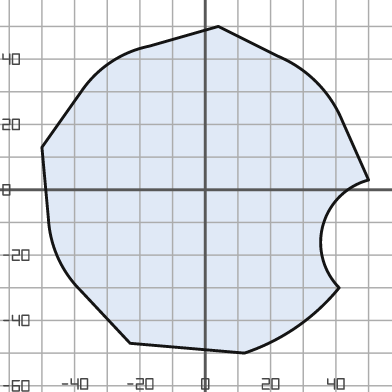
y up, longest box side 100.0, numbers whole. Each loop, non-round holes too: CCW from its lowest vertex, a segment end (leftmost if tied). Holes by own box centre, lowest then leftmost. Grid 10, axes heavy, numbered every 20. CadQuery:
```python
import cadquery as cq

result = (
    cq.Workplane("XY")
    .moveTo(12.0, -50.0)
    .threePointArc((28.0, -42.0), (41.0, -30.0))
    .threePointArc((36.0, -11.0), (50.0, 3.0))
    .lineTo(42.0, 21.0)
    .threePointArc((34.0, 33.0), (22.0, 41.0))
    .lineTo(4.0, 50.0)
    .lineTo(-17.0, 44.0)
    .threePointArc((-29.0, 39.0), (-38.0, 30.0))
    .lineTo(-50.0, 13.0)
    .lineTo(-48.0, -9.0)
    .threePointArc((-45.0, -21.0), (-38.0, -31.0))
    .lineTo(-23.0, -47.0)
    .close()
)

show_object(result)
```